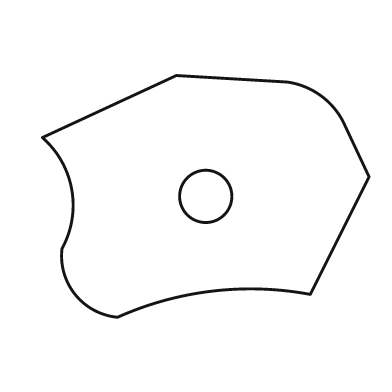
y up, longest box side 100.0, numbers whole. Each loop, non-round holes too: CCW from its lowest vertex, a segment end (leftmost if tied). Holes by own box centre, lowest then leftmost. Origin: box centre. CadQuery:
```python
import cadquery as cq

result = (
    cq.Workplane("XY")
    .moveTo(-27.0, -37.0)
    .threePointArc((2.0, -29.0), (32.0, -30.0))
    .lineTo(50.0, 6.0)
    .lineTo(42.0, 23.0)
    .threePointArc((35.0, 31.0), (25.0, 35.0))
    .lineTo(-9.0, 37.0)
    .lineTo(-50.0, 18.0)
    .threePointArc((-41.0, 2.0), (-44.0, -16.0))
    .threePointArc((-40.0, -30.0), (-27.0, -37.0))
    .close()
    .moveTo(0.0, 0.0)
    .circle(8.0)
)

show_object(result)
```